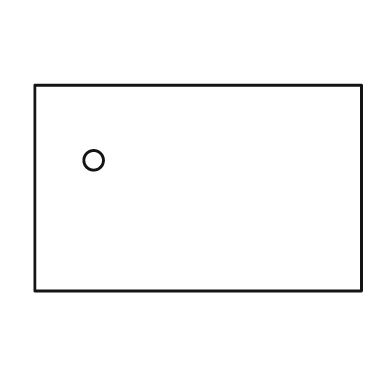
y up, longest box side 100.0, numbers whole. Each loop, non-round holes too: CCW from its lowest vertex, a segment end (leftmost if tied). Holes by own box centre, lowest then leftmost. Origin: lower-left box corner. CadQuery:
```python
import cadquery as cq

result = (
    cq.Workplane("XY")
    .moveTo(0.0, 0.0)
    .lineTo(100.0, 0.0)
    .lineTo(100.0, 63.0)
    .lineTo(0.0, 63.0)
    .close()
    .moveTo(18.0, 40.0)
    .circle(3.0)
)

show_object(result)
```